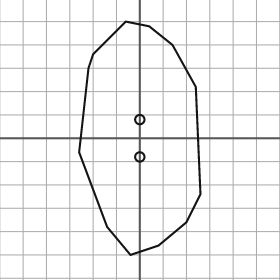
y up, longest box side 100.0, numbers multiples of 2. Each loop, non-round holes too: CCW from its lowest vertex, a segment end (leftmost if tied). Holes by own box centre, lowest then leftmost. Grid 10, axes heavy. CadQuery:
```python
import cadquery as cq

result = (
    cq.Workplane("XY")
    .moveTo(-4.0, -50.0)
    .lineTo(8.0, -46.0)
    .lineTo(20.0, -36.0)
    .lineTo(26.0, -24.0)
    .lineTo(24.0, 22.0)
    .lineTo(14.0, 40.0)
    .lineTo(4.0, 48.0)
    .lineTo(-6.0, 50.0)
    .lineTo(-20.0, 36.0)
    .lineTo(-22.0, 30.0)
    .lineTo(-26.0, -6.0)
    .lineTo(-14.0, -38.0)
    .close()
    .moveTo(0.0, -8.0)
    .circle(2.0)
    .moveTo(0.0, 8.0)
    .circle(2.0)
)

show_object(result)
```